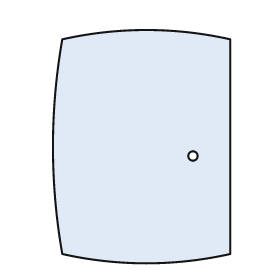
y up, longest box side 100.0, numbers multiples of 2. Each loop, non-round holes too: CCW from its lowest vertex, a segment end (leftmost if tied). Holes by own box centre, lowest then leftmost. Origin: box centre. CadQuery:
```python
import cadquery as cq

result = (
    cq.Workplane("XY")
    .moveTo(-34.0, -46.0)
    .threePointArc((2.0, -50.0), (38.0, -46.0))
    .lineTo(38.0, 46.0)
    .threePointArc((2.0, 50.0), (-34.0, 46.0))
    .threePointArc((-38.0, 0.0), (-34.0, -46.0))
    .close()
    .moveTo(22.0, -4.0)
    .circle(2.0)
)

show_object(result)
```